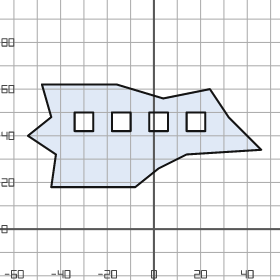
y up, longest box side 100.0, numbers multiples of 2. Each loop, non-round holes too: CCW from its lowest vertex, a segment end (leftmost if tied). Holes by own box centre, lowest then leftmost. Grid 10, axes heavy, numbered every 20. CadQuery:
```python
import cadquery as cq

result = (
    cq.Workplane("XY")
    .moveTo(-44.0, 18.0)
    .lineTo(-8.0, 18.0)
    .lineTo(2.0, 26.0)
    .lineTo(14.0, 32.0)
    .lineTo(46.0, 34.0)
    .lineTo(32.0, 48.0)
    .lineTo(24.0, 60.0)
    .lineTo(4.0, 56.0)
    .lineTo(-16.0, 62.0)
    .lineTo(-48.0, 62.0)
    .lineTo(-44.0, 48.0)
    .lineTo(-54.0, 40.0)
    .lineTo(-42.0, 32.0)
    .close()
    .moveTo(-34.0, 42.0)
    .lineTo(-26.0, 42.0)
    .lineTo(-26.0, 50.0)
    .lineTo(-34.0, 50.0)
    .close()
    .moveTo(-18.0, 42.0)
    .lineTo(-10.0, 42.0)
    .lineTo(-10.0, 50.0)
    .lineTo(-18.0, 50.0)
    .close()
    .moveTo(-2.0, 42.0)
    .lineTo(6.0, 42.0)
    .lineTo(6.0, 50.0)
    .lineTo(-2.0, 50.0)
    .close()
    .moveTo(14.0, 42.0)
    .lineTo(22.0, 42.0)
    .lineTo(22.0, 50.0)
    .lineTo(14.0, 50.0)
    .close()
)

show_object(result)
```